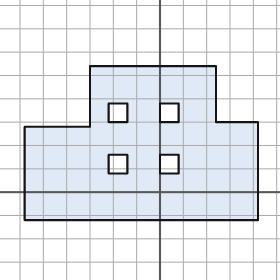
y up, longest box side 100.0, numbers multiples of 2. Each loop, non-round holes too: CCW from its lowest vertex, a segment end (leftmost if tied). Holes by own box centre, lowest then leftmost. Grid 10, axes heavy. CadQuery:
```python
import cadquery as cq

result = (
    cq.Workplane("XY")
    .moveTo(-58.0, -12.0)
    .lineTo(42.0, -12.0)
    .lineTo(42.0, 30.0)
    .lineTo(24.0, 30.0)
    .lineTo(24.0, 54.0)
    .lineTo(-30.0, 54.0)
    .lineTo(-30.0, 28.0)
    .lineTo(-58.0, 28.0)
    .close()
    .moveTo(-22.0, 8.0)
    .lineTo(-14.0, 8.0)
    .lineTo(-14.0, 16.0)
    .lineTo(-22.0, 16.0)
    .close()
    .moveTo(0.0, 8.0)
    .lineTo(8.0, 8.0)
    .lineTo(8.0, 16.0)
    .lineTo(0.0, 16.0)
    .close()
    .moveTo(-22.0, 30.0)
    .lineTo(-14.0, 30.0)
    .lineTo(-14.0, 38.0)
    .lineTo(-22.0, 38.0)
    .close()
    .moveTo(0.0, 30.0)
    .lineTo(8.0, 30.0)
    .lineTo(8.0, 38.0)
    .lineTo(0.0, 38.0)
    .close()
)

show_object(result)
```